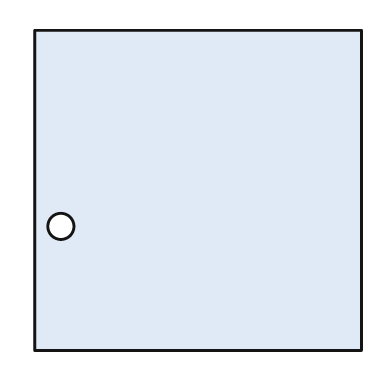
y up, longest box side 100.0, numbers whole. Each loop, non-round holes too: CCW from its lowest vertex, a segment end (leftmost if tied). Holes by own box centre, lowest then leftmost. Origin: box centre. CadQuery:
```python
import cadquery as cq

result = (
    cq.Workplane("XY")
    .moveTo(-50.0, -49.0)
    .lineTo(50.0, -49.0)
    .lineTo(50.0, 49.0)
    .lineTo(-50.0, 49.0)
    .close()
    .moveTo(-42.0, -11.0)
    .circle(4.0)
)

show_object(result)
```